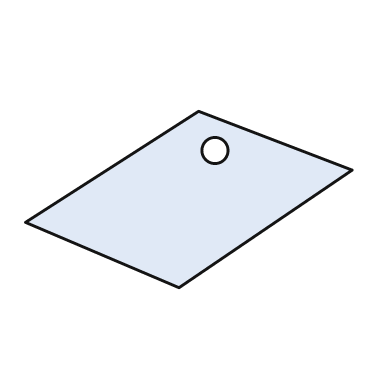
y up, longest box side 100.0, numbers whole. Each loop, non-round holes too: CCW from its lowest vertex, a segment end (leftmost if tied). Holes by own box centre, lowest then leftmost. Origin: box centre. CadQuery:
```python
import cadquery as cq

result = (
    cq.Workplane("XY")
    .moveTo(-3.0, -27.0)
    .lineTo(50.0, 9.0)
    .lineTo(3.0, 27.0)
    .lineTo(-50.0, -7.0)
    .close()
    .moveTo(8.0, 15.0)
    .circle(4.0)
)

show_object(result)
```